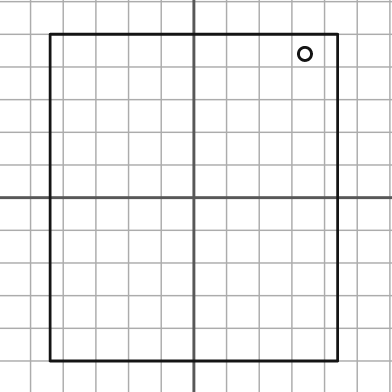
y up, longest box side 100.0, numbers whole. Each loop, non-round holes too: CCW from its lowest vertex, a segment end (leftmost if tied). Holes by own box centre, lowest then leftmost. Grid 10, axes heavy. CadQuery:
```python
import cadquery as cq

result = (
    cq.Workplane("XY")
    .moveTo(-44.0, -50.0)
    .lineTo(44.0, -50.0)
    .lineTo(44.0, 50.0)
    .lineTo(-44.0, 50.0)
    .close()
    .moveTo(34.0, 44.0)
    .circle(2.0)
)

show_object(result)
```